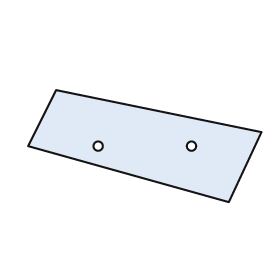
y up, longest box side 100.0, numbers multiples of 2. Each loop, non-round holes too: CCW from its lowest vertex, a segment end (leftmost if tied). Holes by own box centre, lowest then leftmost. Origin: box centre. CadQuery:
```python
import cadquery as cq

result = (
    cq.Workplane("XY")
    .moveTo(36.0, -24.0)
    .lineTo(50.0, 6.0)
    .lineTo(-38.0, 24.0)
    .lineTo(-50.0, 0.0)
    .close()
    .moveTo(-20.0, 0.0)
    .circle(2.0)
    .moveTo(20.0, 0.0)
    .circle(2.0)
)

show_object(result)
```